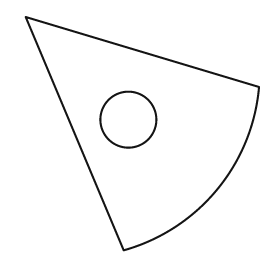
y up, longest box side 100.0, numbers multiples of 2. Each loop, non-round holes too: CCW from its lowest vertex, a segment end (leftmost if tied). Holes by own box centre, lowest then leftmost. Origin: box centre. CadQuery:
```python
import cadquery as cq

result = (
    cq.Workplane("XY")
    .moveTo(-8.0, -50.0)
    .threePointArc((32.0, -24.0), (50.0, 20.0))
    .lineTo(-50.0, 50.0)
    .close()
    .moveTo(-6.0, 6.0)
    .circle(12.0)
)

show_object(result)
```